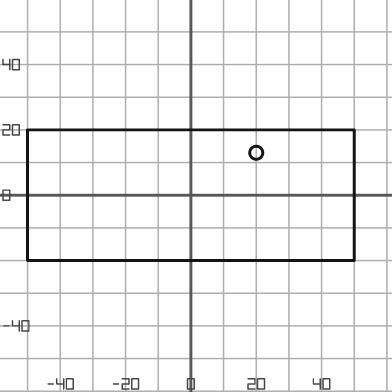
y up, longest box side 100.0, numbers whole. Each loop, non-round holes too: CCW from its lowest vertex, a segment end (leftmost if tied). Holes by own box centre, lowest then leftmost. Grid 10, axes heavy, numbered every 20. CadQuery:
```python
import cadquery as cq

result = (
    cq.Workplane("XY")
    .moveTo(-50.0, -20.0)
    .lineTo(50.0, -20.0)
    .lineTo(50.0, 20.0)
    .lineTo(-50.0, 20.0)
    .close()
    .moveTo(20.0, 13.0)
    .circle(2.0)
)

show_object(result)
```